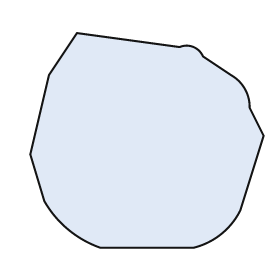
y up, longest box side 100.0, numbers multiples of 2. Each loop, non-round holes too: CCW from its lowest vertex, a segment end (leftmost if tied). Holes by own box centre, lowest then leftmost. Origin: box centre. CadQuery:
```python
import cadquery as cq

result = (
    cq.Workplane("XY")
    .moveTo(-20.0, -46.0)
    .lineTo(20.0, -46.0)
    .threePointArc((32.0, -40.0), (40.0, -30.0))
    .lineTo(50.0, 2.0)
    .lineTo(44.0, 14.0)
    .threePointArc((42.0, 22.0), (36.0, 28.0))
    .lineTo(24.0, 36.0)
    .threePointArc((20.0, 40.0), (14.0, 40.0))
    .lineTo(-30.0, 46.0)
    .lineTo(-42.0, 28.0)
    .lineTo(-50.0, -6.0)
    .lineTo(-44.0, -26.0)
    .threePointArc((-34.0, -38.0), (-20.0, -46.0))
    .close()
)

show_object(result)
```